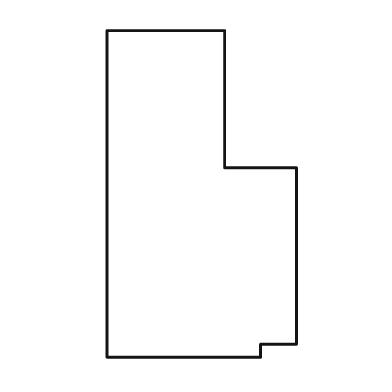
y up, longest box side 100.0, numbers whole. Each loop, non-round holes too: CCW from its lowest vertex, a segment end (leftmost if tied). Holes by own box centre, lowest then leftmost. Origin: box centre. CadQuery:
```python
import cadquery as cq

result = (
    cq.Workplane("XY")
    .moveTo(-29.0, -50.0)
    .lineTo(18.0, -50.0)
    .lineTo(18.0, -46.0)
    .lineTo(29.0, -46.0)
    .lineTo(29.0, 8.0)
    .lineTo(7.0, 8.0)
    .lineTo(7.0, 50.0)
    .lineTo(-29.0, 50.0)
    .close()
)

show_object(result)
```